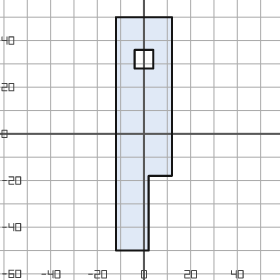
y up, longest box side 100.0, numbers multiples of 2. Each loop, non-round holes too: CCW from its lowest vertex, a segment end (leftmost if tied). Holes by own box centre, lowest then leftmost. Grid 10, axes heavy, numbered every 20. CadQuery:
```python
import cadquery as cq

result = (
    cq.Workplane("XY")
    .moveTo(-12.0, -50.0)
    .lineTo(2.0, -50.0)
    .lineTo(2.0, -18.0)
    .lineTo(12.0, -18.0)
    .lineTo(12.0, 50.0)
    .lineTo(-12.0, 50.0)
    .close()
    .moveTo(-4.0, 28.0)
    .lineTo(4.0, 28.0)
    .lineTo(4.0, 36.0)
    .lineTo(-4.0, 36.0)
    .close()
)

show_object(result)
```